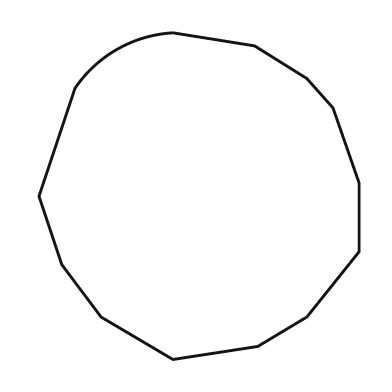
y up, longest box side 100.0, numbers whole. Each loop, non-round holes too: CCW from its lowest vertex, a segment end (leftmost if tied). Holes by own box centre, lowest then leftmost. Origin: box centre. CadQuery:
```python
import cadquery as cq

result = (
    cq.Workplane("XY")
    .moveTo(-8.0, -50.0)
    .lineTo(18.0, -46.0)
    .lineTo(33.0, -37.0)
    .lineTo(49.0, -17.0)
    .lineTo(49.0, 4.0)
    .lineTo(41.0, 27.0)
    .lineTo(33.0, 36.0)
    .lineTo(17.0, 46.0)
    .lineTo(-8.0, 50.0)
    .threePointArc((-25.0, 45.0), (-38.0, 33.0))
    .lineTo(-49.0, 0.0)
    .lineTo(-42.0, -21.0)
    .lineTo(-30.0, -37.0)
    .close()
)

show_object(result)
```